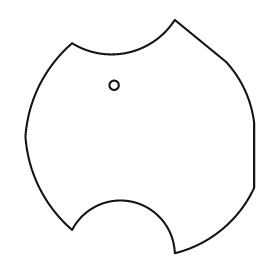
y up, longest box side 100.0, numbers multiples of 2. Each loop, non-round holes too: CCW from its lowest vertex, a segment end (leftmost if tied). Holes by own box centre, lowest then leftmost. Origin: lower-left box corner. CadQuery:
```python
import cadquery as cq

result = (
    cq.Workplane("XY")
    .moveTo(64.0, 0.0)
    .threePointArc((84.0, 10.0), (98.0, 28.0))
    .lineTo(98.0, 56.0)
    .threePointArc((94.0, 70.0), (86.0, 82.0))
    .lineTo(64.0, 100.0)
    .threePointArc((44.0, 86.0), (20.0, 90.0))
    .threePointArc((6.0, 72.0), (0.0, 50.0))
    .threePointArc((6.0, 28.0), (20.0, 10.0))
    .threePointArc((46.0, 22.0), (64.0, 0.0))
    .close()
    .moveTo(38.0, 72.0)
    .circle(2.0)
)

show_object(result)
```